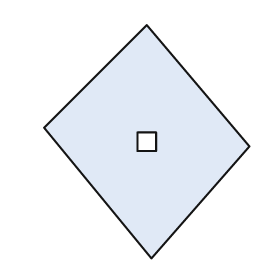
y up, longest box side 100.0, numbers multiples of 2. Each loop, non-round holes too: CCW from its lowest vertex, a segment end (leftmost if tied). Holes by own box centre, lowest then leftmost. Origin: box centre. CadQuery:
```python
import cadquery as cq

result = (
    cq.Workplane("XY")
    .moveTo(2.0, -50.0)
    .lineTo(44.0, -2.0)
    .lineTo(0.0, 50.0)
    .lineTo(-44.0, 6.0)
    .close()
    .moveTo(-4.0, -4.0)
    .lineTo(4.0, -4.0)
    .lineTo(4.0, 4.0)
    .lineTo(-4.0, 4.0)
    .close()
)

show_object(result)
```